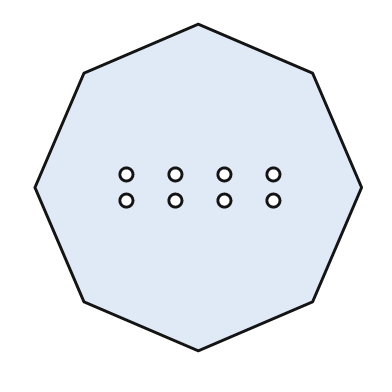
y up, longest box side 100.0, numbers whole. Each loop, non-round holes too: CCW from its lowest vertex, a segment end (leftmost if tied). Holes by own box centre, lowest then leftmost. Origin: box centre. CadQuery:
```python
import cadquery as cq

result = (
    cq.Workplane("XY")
    .moveTo(0.0, -50.0)
    .lineTo(35.0, -35.0)
    .lineTo(50.0, 0.0)
    .lineTo(35.0, 35.0)
    .lineTo(0.0, 50.0)
    .lineTo(-35.0, 35.0)
    .lineTo(-50.0, 0.0)
    .lineTo(-35.0, -35.0)
    .close()
    .moveTo(-22.0, -4.0)
    .circle(2.0)
    .moveTo(-7.0, -4.0)
    .circle(2.0)
    .moveTo(8.0, -4.0)
    .circle(2.0)
    .moveTo(23.0, -4.0)
    .circle(2.0)
    .moveTo(-22.0, 4.0)
    .circle(2.0)
    .moveTo(-7.0, 4.0)
    .circle(2.0)
    .moveTo(8.0, 4.0)
    .circle(2.0)
    .moveTo(23.0, 4.0)
    .circle(2.0)
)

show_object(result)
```